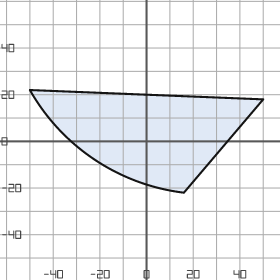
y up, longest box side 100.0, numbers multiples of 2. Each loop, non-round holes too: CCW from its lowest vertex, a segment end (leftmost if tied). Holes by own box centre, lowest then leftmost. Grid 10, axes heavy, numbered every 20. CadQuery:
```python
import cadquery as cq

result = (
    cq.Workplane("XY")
    .moveTo(16.0, -22.0)
    .lineTo(50.0, 18.0)
    .lineTo(-50.0, 22.0)
    .threePointArc((-22.0, -8.0), (16.0, -22.0))
    .close()
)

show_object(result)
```